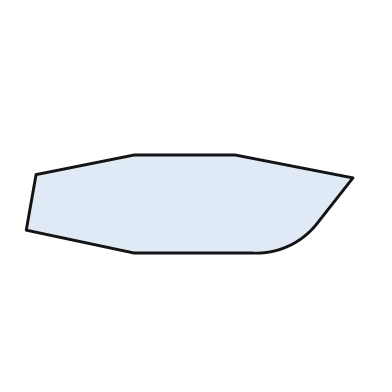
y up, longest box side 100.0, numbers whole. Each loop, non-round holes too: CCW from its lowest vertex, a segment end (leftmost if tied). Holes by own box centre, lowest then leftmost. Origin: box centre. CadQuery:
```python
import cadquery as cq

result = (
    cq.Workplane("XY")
    .moveTo(-17.0, -15.0)
    .lineTo(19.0, -15.0)
    .threePointArc((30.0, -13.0), (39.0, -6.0))
    .lineTo(50.0, 8.0)
    .lineTo(14.0, 15.0)
    .lineTo(-17.0, 15.0)
    .lineTo(-47.0, 9.0)
    .lineTo(-50.0, -8.0)
    .close()
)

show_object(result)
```